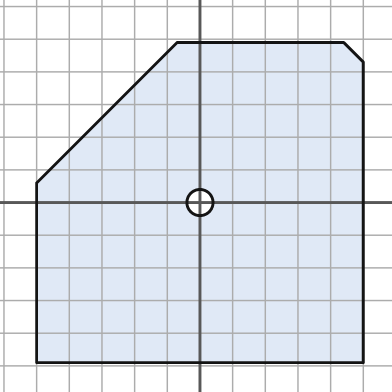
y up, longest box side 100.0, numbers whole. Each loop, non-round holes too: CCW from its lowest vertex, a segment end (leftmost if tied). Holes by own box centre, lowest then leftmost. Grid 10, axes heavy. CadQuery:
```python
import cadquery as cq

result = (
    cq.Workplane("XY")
    .moveTo(-50.0, -49.0)
    .lineTo(50.0, -49.0)
    .lineTo(50.0, 43.0)
    .lineTo(44.0, 49.0)
    .lineTo(-7.0, 49.0)
    .lineTo(-50.0, 6.0)
    .close()
    .moveTo(0.0, 0.0)
    .circle(4.0)
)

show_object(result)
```